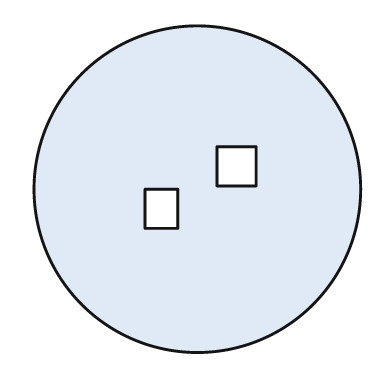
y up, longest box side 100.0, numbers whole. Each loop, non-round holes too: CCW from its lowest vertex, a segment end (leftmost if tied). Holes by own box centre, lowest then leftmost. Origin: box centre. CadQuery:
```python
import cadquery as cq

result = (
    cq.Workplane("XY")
    .moveTo(0.0, 0.0)
    .circle(50.0)
    .moveTo(-16.0, -12.0)
    .lineTo(-6.0, -12.0)
    .lineTo(-6.0, 0.0)
    .lineTo(-16.0, 0.0)
    .close()
    .moveTo(6.0, 1.0)
    .lineTo(18.0, 1.0)
    .lineTo(18.0, 13.0)
    .lineTo(6.0, 13.0)
    .close()
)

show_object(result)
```